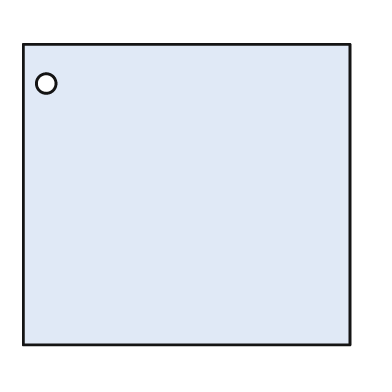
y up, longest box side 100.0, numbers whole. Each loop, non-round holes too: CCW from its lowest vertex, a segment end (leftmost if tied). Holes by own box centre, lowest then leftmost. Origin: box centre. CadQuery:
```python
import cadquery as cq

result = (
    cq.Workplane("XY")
    .moveTo(-50.0, -46.0)
    .lineTo(50.0, -46.0)
    .lineTo(50.0, 46.0)
    .lineTo(-50.0, 46.0)
    .close()
    .moveTo(-43.0, 34.0)
    .circle(3.0)
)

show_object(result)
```